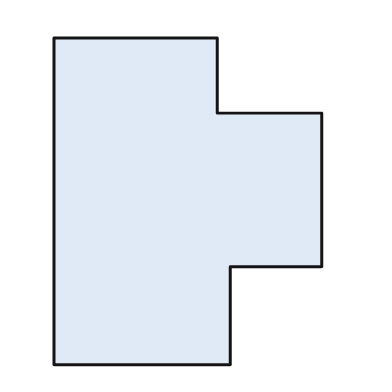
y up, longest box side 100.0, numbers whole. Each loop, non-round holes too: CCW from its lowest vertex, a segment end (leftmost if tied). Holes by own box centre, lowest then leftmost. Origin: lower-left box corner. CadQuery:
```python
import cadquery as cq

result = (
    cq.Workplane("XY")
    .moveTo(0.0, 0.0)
    .lineTo(54.0, 0.0)
    .lineTo(54.0, 30.0)
    .lineTo(82.0, 30.0)
    .lineTo(82.0, 77.0)
    .lineTo(50.0, 77.0)
    .lineTo(50.0, 100.0)
    .lineTo(0.0, 100.0)
    .close()
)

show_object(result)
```